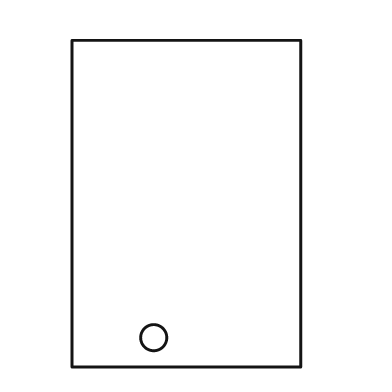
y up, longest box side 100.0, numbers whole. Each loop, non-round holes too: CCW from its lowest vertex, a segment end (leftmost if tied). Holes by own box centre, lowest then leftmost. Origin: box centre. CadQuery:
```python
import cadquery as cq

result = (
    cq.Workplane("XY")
    .moveTo(-35.0, -50.0)
    .lineTo(35.0, -50.0)
    .lineTo(35.0, 50.0)
    .lineTo(-35.0, 50.0)
    .close()
    .moveTo(-10.0, -41.0)
    .circle(4.0)
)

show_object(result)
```